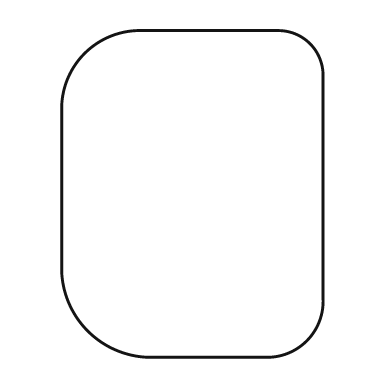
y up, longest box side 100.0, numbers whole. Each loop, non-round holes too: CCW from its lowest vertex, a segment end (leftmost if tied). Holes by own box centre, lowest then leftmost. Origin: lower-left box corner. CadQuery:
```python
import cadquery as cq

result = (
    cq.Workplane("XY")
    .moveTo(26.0, 0.0)
    .lineTo(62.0, 0.0)
    .threePointArc((75.0, 5.0), (80.0, 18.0))
    .lineTo(80.0, 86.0)
    .threePointArc((76.0, 96.0), (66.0, 100.0))
    .lineTo(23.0, 100.0)
    .threePointArc((7.0, 93.0), (0.0, 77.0))
    .lineTo(0.0, 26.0)
    .threePointArc((8.0, 8.0), (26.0, 0.0))
    .close()
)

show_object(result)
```